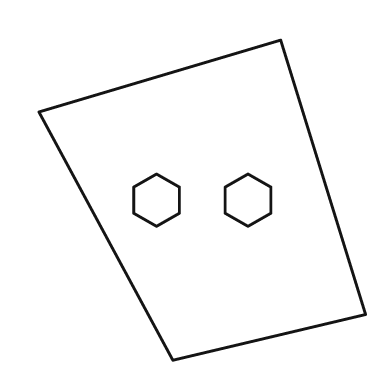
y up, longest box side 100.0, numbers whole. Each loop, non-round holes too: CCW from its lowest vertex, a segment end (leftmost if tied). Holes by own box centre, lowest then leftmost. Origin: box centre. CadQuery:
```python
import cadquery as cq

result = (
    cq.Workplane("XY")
    .moveTo(-9.0, -49.0)
    .lineTo(50.0, -35.0)
    .lineTo(24.0, 49.0)
    .lineTo(-50.0, 27.0)
    .close()
    .moveTo(-14.0, -8.0)
    .lineTo(-7.0, -4.0)
    .lineTo(-7.0, 4.0)
    .lineTo(-14.0, 8.0)
    .lineTo(-21.0, 4.0)
    .lineTo(-21.0, -4.0)
    .close()
    .moveTo(14.0, -8.0)
    .lineTo(21.0, -4.0)
    .lineTo(21.0, 4.0)
    .lineTo(14.0, 8.0)
    .lineTo(7.0, 4.0)
    .lineTo(7.0, -4.0)
    .close()
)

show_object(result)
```